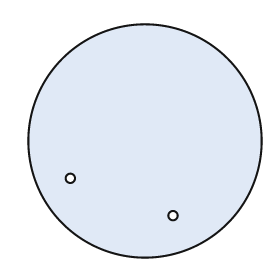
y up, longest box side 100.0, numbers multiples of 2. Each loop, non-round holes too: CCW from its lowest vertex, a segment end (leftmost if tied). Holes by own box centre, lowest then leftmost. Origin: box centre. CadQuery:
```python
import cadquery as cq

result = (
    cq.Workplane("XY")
    .moveTo(0.0, 0.0)
    .circle(50.0)
    .moveTo(12.0, -32.0)
    .circle(2.0)
    .moveTo(-32.0, -16.0)
    .circle(2.0)
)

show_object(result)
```